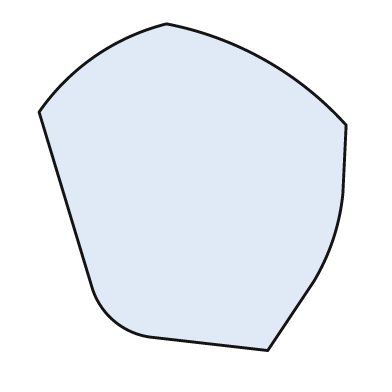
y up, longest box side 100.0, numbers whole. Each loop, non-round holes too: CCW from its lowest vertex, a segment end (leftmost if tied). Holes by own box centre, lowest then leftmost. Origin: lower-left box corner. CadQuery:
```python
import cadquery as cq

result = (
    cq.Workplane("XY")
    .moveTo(70.0, 0.0)
    .lineTo(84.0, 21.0)
    .threePointArc((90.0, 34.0), (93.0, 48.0))
    .lineTo(94.0, 69.0)
    .threePointArc((69.0, 89.0), (39.0, 100.0))
    .threePointArc((17.0, 90.0), (0.0, 73.0))
    .lineTo(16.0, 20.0)
    .threePointArc((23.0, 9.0), (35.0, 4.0))
    .close()
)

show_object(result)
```